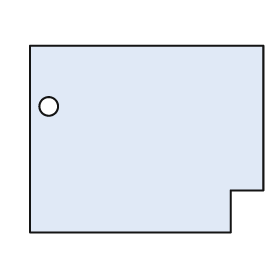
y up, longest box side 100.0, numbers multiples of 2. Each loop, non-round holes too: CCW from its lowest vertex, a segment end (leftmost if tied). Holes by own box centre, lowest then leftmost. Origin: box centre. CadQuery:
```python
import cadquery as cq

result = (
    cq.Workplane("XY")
    .moveTo(-50.0, -40.0)
    .lineTo(36.0, -40.0)
    .lineTo(36.0, -22.0)
    .lineTo(50.0, -22.0)
    .lineTo(50.0, 40.0)
    .lineTo(-50.0, 40.0)
    .close()
    .moveTo(-42.0, 14.0)
    .circle(4.0)
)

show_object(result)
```